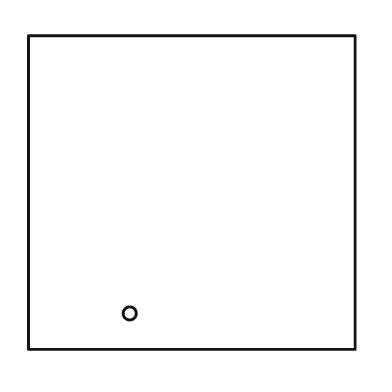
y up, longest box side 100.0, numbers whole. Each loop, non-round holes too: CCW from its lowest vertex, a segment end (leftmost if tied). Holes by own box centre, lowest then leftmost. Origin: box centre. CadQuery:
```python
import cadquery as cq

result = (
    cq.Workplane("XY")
    .moveTo(-50.0, -48.0)
    .lineTo(50.0, -48.0)
    .lineTo(50.0, 48.0)
    .lineTo(-50.0, 48.0)
    .close()
    .moveTo(-19.0, -37.0)
    .circle(2.0)
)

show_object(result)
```